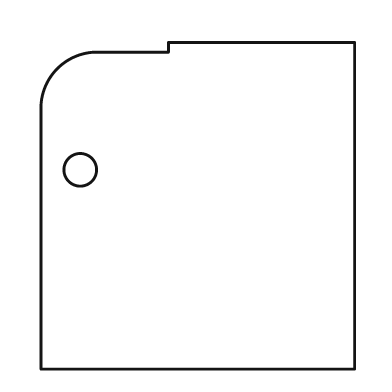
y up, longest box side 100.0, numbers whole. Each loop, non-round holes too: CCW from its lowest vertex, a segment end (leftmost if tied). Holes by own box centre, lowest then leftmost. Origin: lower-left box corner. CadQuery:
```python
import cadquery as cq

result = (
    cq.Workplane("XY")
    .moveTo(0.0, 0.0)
    .lineTo(96.0, 0.0)
    .lineTo(96.0, 100.0)
    .lineTo(39.0, 100.0)
    .lineTo(39.0, 97.0)
    .lineTo(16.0, 97.0)
    .threePointArc((5.0, 92.0), (0.0, 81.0))
    .close()
    .moveTo(12.0, 61.0)
    .circle(5.0)
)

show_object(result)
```